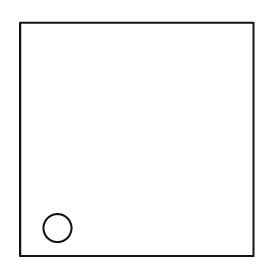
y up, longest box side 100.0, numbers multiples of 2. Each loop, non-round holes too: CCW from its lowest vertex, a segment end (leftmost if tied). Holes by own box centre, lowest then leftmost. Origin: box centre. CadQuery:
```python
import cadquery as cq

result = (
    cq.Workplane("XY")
    .moveTo(-50.0, -50.0)
    .lineTo(50.0, -50.0)
    .lineTo(50.0, 50.0)
    .lineTo(-50.0, 50.0)
    .close()
    .moveTo(-34.0, -38.0)
    .circle(6.0)
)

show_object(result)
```